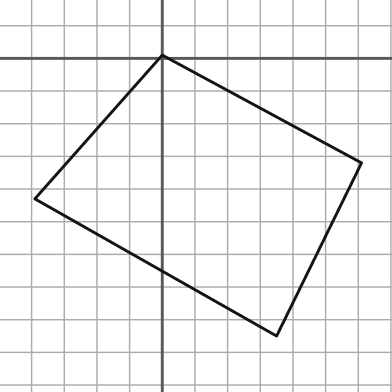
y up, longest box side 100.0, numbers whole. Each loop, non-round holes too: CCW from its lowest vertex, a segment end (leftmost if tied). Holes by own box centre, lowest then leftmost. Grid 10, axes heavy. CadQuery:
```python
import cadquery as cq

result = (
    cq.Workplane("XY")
    .moveTo(35.0, -85.0)
    .lineTo(61.0, -32.0)
    .lineTo(0.0, 1.0)
    .lineTo(-39.0, -43.0)
    .close()
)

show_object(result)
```